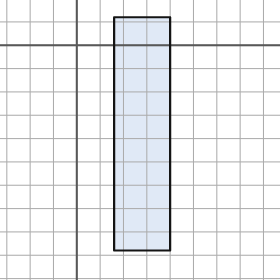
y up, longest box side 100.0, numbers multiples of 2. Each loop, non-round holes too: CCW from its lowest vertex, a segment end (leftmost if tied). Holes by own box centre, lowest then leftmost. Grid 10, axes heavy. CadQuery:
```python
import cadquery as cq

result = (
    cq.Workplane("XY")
    .moveTo(16.0, -88.0)
    .lineTo(40.0, -88.0)
    .lineTo(40.0, 12.0)
    .lineTo(16.0, 12.0)
    .close()
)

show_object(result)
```